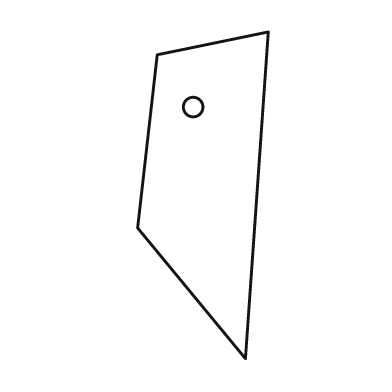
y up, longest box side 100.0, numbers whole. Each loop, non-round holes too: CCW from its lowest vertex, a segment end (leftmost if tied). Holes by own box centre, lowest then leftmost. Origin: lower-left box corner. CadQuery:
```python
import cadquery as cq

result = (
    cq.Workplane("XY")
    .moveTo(33.0, 0.0)
    .lineTo(40.0, 100.0)
    .lineTo(6.0, 93.0)
    .lineTo(0.0, 40.0)
    .close()
    .moveTo(17.0, 77.0)
    .circle(3.0)
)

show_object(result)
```